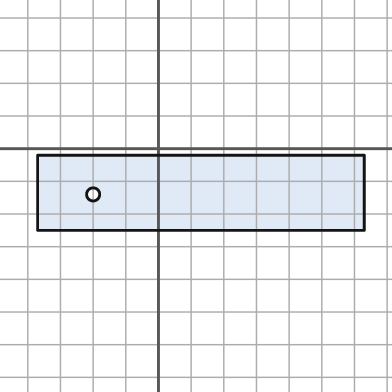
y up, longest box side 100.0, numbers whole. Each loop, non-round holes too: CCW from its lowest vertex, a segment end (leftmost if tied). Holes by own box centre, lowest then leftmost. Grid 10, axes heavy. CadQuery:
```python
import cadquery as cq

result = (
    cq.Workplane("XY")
    .moveTo(-37.0, -25.0)
    .lineTo(63.0, -25.0)
    .lineTo(63.0, -2.0)
    .lineTo(-37.0, -2.0)
    .close()
    .moveTo(-20.0, -14.0)
    .circle(2.0)
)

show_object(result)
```